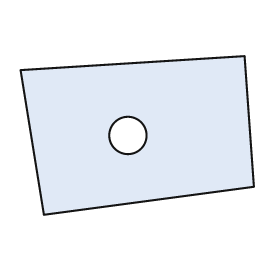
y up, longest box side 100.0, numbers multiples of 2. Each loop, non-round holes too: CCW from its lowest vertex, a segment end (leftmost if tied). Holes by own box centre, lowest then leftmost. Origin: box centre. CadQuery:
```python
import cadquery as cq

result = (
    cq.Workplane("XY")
    .moveTo(-40.0, -34.0)
    .lineTo(50.0, -22.0)
    .lineTo(46.0, 34.0)
    .lineTo(-50.0, 28.0)
    .close()
    .moveTo(-4.0, 0.0)
    .circle(8.0)
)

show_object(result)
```